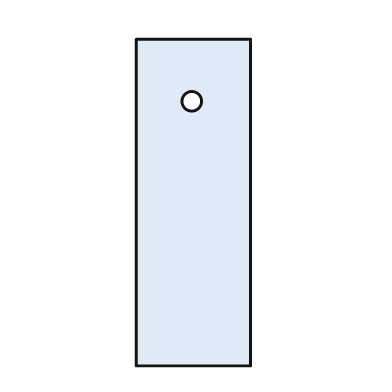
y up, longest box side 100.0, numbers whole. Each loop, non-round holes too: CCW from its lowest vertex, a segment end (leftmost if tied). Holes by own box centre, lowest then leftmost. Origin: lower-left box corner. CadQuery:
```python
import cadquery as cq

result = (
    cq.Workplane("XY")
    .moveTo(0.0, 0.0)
    .lineTo(35.0, 0.0)
    .lineTo(35.0, 100.0)
    .lineTo(0.0, 100.0)
    .close()
    .moveTo(17.0, 81.0)
    .circle(3.0)
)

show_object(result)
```